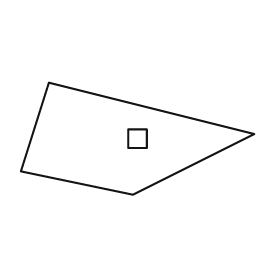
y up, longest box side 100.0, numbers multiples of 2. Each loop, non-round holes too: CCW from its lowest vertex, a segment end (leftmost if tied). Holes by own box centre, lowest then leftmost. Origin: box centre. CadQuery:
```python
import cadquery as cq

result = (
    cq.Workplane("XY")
    .moveTo(-2.0, -24.0)
    .lineTo(50.0, 2.0)
    .lineTo(-38.0, 24.0)
    .lineTo(-50.0, -14.0)
    .close()
    .moveTo(-4.0, -4.0)
    .lineTo(4.0, -4.0)
    .lineTo(4.0, 4.0)
    .lineTo(-4.0, 4.0)
    .close()
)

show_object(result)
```